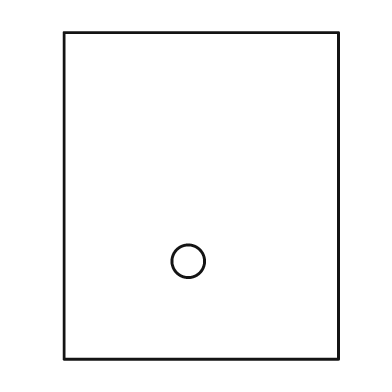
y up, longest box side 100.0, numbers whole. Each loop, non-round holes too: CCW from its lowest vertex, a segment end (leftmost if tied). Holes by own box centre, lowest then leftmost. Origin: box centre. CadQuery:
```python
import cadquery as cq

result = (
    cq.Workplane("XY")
    .moveTo(-42.0, -50.0)
    .lineTo(42.0, -50.0)
    .lineTo(42.0, 50.0)
    .lineTo(-42.0, 50.0)
    .close()
    .moveTo(-4.0, -20.0)
    .circle(5.0)
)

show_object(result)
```